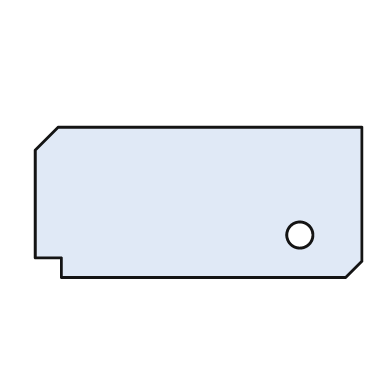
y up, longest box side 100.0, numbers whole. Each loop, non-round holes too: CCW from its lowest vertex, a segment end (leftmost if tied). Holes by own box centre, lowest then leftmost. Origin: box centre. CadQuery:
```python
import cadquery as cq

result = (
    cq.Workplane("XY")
    .moveTo(-42.0, -23.0)
    .lineTo(45.0, -23.0)
    .lineTo(50.0, -18.0)
    .lineTo(50.0, 23.0)
    .lineTo(-43.0, 23.0)
    .lineTo(-50.0, 16.0)
    .lineTo(-50.0, -17.0)
    .lineTo(-42.0, -17.0)
    .close()
    .moveTo(31.0, -10.0)
    .circle(4.0)
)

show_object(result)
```